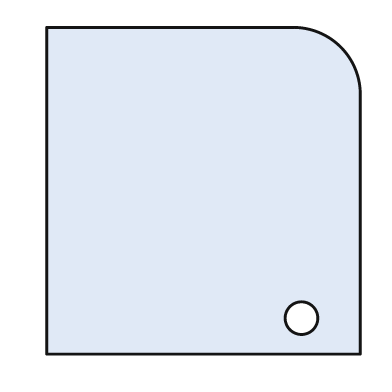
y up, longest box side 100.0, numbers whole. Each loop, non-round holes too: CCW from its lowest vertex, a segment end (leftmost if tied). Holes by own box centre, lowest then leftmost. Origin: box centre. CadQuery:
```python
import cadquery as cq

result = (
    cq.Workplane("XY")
    .moveTo(-48.0, -50.0)
    .lineTo(48.0, -50.0)
    .lineTo(48.0, 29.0)
    .threePointArc((42.0, 44.0), (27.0, 50.0))
    .lineTo(-48.0, 50.0)
    .close()
    .moveTo(30.0, -39.0)
    .circle(5.0)
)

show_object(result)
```